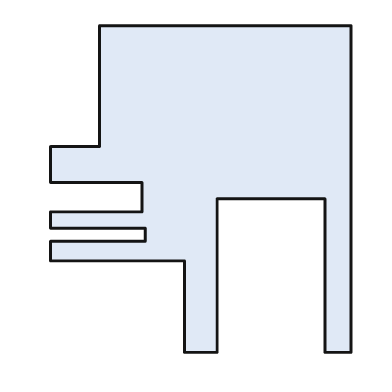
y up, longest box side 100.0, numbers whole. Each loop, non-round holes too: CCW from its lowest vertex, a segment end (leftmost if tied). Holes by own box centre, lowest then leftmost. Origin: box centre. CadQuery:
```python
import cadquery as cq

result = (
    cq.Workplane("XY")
    .moveTo(-5.0, -50.0)
    .lineTo(5.0, -50.0)
    .lineTo(5.0, -3.0)
    .lineTo(38.0, -3.0)
    .lineTo(38.0, -50.0)
    .lineTo(46.0, -50.0)
    .lineTo(46.0, 50.0)
    .lineTo(-31.0, 50.0)
    .lineTo(-31.0, 13.0)
    .lineTo(-46.0, 13.0)
    .lineTo(-46.0, 2.0)
    .lineTo(-18.0, 2.0)
    .lineTo(-18.0, -7.0)
    .lineTo(-46.0, -7.0)
    .lineTo(-46.0, -12.0)
    .lineTo(-17.0, -12.0)
    .lineTo(-17.0, -16.0)
    .lineTo(-46.0, -16.0)
    .lineTo(-46.0, -22.0)
    .lineTo(-5.0, -22.0)
    .close()
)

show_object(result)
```